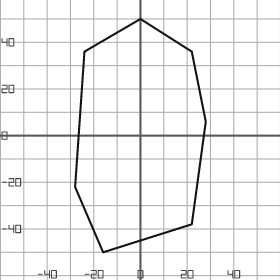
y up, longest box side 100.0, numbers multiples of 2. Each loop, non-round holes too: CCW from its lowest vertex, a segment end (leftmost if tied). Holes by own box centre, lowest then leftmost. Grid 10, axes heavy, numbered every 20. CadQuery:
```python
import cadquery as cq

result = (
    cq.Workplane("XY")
    .moveTo(-16.0, -50.0)
    .lineTo(22.0, -38.0)
    .lineTo(28.0, 6.0)
    .lineTo(22.0, 36.0)
    .lineTo(0.0, 50.0)
    .lineTo(-24.0, 36.0)
    .lineTo(-28.0, -22.0)
    .close()
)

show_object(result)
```